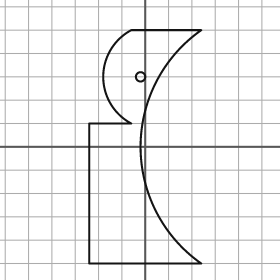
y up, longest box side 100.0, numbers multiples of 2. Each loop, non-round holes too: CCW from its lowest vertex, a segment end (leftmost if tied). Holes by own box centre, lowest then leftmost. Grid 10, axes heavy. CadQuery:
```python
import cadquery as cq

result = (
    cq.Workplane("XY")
    .moveTo(-24.0, -50.0)
    .lineTo(24.0, -50.0)
    .threePointArc((-2.0, 0.0), (24.0, 50.0))
    .lineTo(-6.0, 50.0)
    .threePointArc((-18.0, 30.0), (-6.0, 10.0))
    .lineTo(-24.0, 10.0)
    .close()
    .moveTo(-2.0, 30.0)
    .circle(2.0)
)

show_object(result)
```